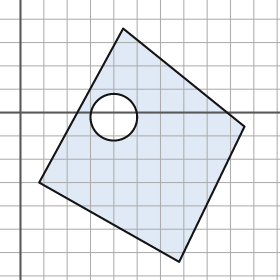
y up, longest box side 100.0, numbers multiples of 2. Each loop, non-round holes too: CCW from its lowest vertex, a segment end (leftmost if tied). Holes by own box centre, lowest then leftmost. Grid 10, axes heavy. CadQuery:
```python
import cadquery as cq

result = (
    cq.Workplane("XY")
    .moveTo(68.0, -64.0)
    .lineTo(96.0, -6.0)
    .lineTo(44.0, 36.0)
    .lineTo(8.0, -30.0)
    .close()
    .moveTo(40.0, -2.0)
    .circle(10.0)
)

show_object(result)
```